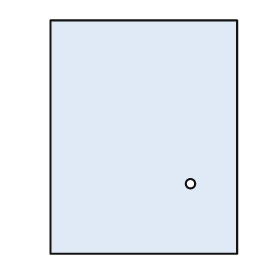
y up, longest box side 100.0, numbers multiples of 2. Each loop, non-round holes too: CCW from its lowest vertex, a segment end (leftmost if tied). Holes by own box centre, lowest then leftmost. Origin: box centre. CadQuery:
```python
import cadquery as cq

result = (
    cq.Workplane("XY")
    .moveTo(-40.0, -50.0)
    .lineTo(40.0, -50.0)
    .lineTo(40.0, 50.0)
    .lineTo(-40.0, 50.0)
    .close()
    .moveTo(20.0, -20.0)
    .circle(2.0)
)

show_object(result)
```